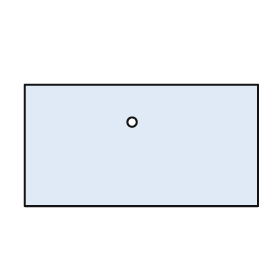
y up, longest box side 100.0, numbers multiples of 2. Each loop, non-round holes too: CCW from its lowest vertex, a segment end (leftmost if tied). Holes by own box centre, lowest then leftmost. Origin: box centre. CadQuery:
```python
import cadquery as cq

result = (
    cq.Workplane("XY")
    .moveTo(-50.0, -26.0)
    .lineTo(50.0, -26.0)
    .lineTo(50.0, 26.0)
    .lineTo(-50.0, 26.0)
    .close()
    .moveTo(-4.0, 10.0)
    .circle(2.0)
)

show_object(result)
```